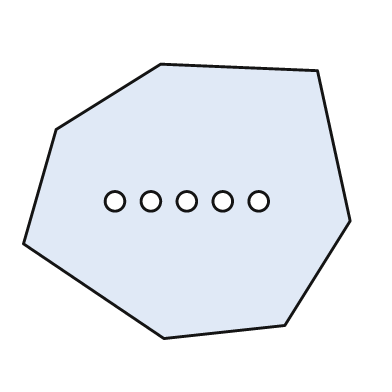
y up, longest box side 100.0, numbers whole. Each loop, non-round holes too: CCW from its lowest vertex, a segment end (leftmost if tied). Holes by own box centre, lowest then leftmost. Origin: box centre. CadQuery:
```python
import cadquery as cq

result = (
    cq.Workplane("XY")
    .moveTo(-7.0, -42.0)
    .lineTo(30.0, -38.0)
    .lineTo(50.0, -6.0)
    .lineTo(40.0, 40.0)
    .lineTo(-8.0, 42.0)
    .lineTo(-40.0, 22.0)
    .lineTo(-50.0, -13.0)
    .close()
    .moveTo(-22.0, 0.0)
    .circle(3.0)
    .moveTo(-11.0, 0.0)
    .circle(3.0)
    .moveTo(0.0, 0.0)
    .circle(3.0)
    .moveTo(11.0, 0.0)
    .circle(3.0)
    .moveTo(22.0, 0.0)
    .circle(3.0)
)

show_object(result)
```